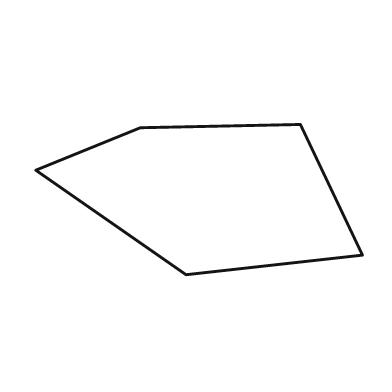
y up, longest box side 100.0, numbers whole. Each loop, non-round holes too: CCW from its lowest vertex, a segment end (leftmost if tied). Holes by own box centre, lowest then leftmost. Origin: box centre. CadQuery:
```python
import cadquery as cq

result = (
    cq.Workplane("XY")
    .moveTo(-4.0, -23.0)
    .lineTo(50.0, -17.0)
    .lineTo(31.0, 23.0)
    .lineTo(-18.0, 22.0)
    .lineTo(-50.0, 9.0)
    .close()
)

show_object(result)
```